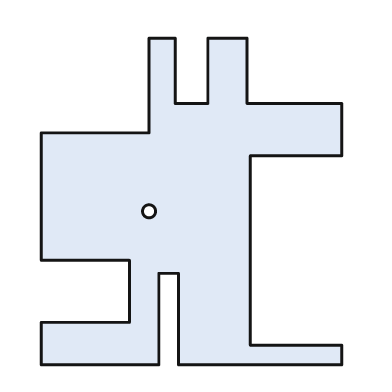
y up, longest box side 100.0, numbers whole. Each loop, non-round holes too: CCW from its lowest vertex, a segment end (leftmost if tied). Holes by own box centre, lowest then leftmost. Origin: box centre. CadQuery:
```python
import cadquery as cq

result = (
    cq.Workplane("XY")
    .moveTo(-46.0, -50.0)
    .lineTo(-10.0, -50.0)
    .lineTo(-10.0, -22.0)
    .lineTo(-4.0, -22.0)
    .lineTo(-4.0, -50.0)
    .lineTo(46.0, -50.0)
    .lineTo(46.0, -44.0)
    .lineTo(18.0, -44.0)
    .lineTo(18.0, 14.0)
    .lineTo(46.0, 14.0)
    .lineTo(46.0, 30.0)
    .lineTo(17.0, 30.0)
    .lineTo(17.0, 50.0)
    .lineTo(5.0, 50.0)
    .lineTo(5.0, 30.0)
    .lineTo(-5.0, 30.0)
    .lineTo(-5.0, 50.0)
    .lineTo(-13.0, 50.0)
    .lineTo(-13.0, 21.0)
    .lineTo(-46.0, 21.0)
    .lineTo(-46.0, -18.0)
    .lineTo(-19.0, -18.0)
    .lineTo(-19.0, -37.0)
    .lineTo(-46.0, -37.0)
    .close()
    .moveTo(-13.0, -3.0)
    .circle(2.0)
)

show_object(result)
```